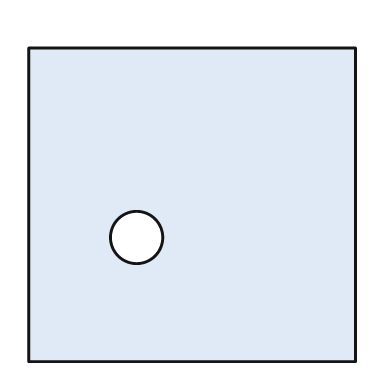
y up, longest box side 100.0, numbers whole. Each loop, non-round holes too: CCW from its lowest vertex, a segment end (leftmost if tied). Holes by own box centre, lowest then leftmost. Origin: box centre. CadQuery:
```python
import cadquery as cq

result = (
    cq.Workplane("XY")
    .moveTo(-50.0, -48.0)
    .lineTo(50.0, -48.0)
    .lineTo(50.0, 48.0)
    .lineTo(-50.0, 48.0)
    .close()
    .moveTo(-17.0, -10.0)
    .circle(8.0)
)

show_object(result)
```